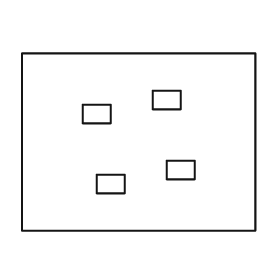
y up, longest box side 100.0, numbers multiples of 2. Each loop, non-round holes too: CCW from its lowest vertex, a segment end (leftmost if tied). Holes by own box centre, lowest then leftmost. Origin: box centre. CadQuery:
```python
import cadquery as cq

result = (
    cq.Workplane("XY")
    .moveTo(-50.0, -38.0)
    .lineTo(50.0, -38.0)
    .lineTo(50.0, 38.0)
    .lineTo(-50.0, 38.0)
    .close()
    .moveTo(-18.0, -22.0)
    .lineTo(-6.0, -22.0)
    .lineTo(-6.0, -14.0)
    .lineTo(-18.0, -14.0)
    .close()
    .moveTo(12.0, -16.0)
    .lineTo(24.0, -16.0)
    .lineTo(24.0, -8.0)
    .lineTo(12.0, -8.0)
    .close()
    .moveTo(-24.0, 8.0)
    .lineTo(-12.0, 8.0)
    .lineTo(-12.0, 16.0)
    .lineTo(-24.0, 16.0)
    .close()
    .moveTo(6.0, 14.0)
    .lineTo(18.0, 14.0)
    .lineTo(18.0, 22.0)
    .lineTo(6.0, 22.0)
    .close()
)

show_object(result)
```